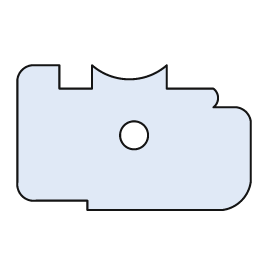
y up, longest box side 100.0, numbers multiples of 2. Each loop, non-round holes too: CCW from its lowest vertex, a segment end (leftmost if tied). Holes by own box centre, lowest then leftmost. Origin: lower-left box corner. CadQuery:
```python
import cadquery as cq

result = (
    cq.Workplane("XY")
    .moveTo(30.0, 0.0)
    .lineTo(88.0, 0.0)
    .threePointArc((96.0, 4.0), (100.0, 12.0))
    .lineTo(100.0, 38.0)
    .threePointArc((98.0, 42.0), (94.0, 44.0))
    .lineTo(84.0, 44.0)
    .threePointArc((86.0, 48.0), (84.0, 52.0))
    .lineTo(64.0, 52.0)
    .lineTo(64.0, 62.0)
    .threePointArc((48.0, 56.0), (32.0, 62.0))
    .lineTo(32.0, 52.0)
    .lineTo(18.0, 52.0)
    .lineTo(18.0, 62.0)
    .lineTo(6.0, 62.0)
    .threePointArc((2.0, 60.0), (0.0, 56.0))
    .lineTo(0.0, 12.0)
    .threePointArc((2.0, 6.0), (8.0, 4.0))
    .lineTo(30.0, 4.0)
    .close()
    .moveTo(50.0, 32.0)
    .circle(6.0)
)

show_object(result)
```